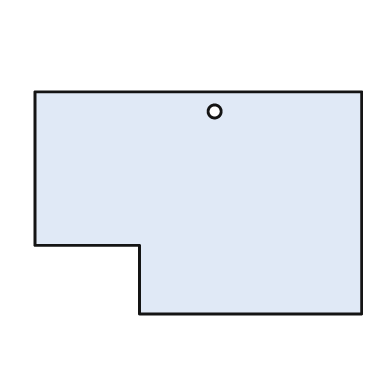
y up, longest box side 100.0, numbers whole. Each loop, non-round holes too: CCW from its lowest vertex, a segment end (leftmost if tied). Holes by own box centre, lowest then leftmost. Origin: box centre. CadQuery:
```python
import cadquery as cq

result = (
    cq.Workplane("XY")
    .moveTo(-18.0, -34.0)
    .lineTo(50.0, -34.0)
    .lineTo(50.0, 34.0)
    .lineTo(-50.0, 34.0)
    .lineTo(-50.0, -13.0)
    .lineTo(-18.0, -13.0)
    .close()
    .moveTo(5.0, 28.0)
    .circle(2.0)
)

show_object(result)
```